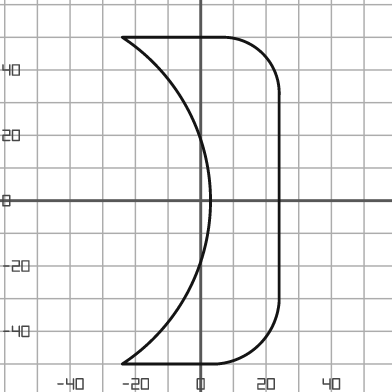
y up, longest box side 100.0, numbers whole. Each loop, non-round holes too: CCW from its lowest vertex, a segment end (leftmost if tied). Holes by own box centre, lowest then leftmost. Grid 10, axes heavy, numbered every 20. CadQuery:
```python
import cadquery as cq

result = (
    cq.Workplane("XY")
    .moveTo(-24.0, -50.0)
    .lineTo(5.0, -50.0)
    .threePointArc((18.0, -44.0), (24.0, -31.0))
    .lineTo(24.0, 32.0)
    .threePointArc((19.0, 45.0), (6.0, 50.0))
    .lineTo(-24.0, 50.0)
    .threePointArc((3.0, 0.0), (-24.0, -50.0))
    .close()
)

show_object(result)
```